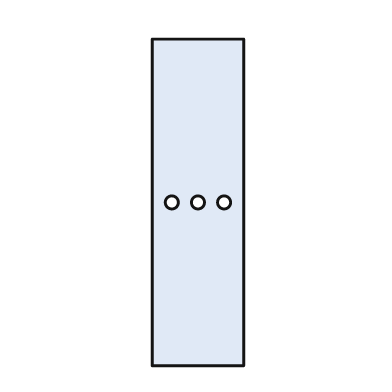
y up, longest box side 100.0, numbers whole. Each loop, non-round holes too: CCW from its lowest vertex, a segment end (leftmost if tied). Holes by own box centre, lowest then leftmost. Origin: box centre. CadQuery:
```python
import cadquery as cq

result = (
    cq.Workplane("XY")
    .moveTo(-14.0, -50.0)
    .lineTo(14.0, -50.0)
    .lineTo(14.0, 50.0)
    .lineTo(-14.0, 50.0)
    .close()
    .moveTo(-8.0, 0.0)
    .circle(2.0)
    .moveTo(0.0, 0.0)
    .circle(2.0)
    .moveTo(8.0, 0.0)
    .circle(2.0)
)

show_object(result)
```